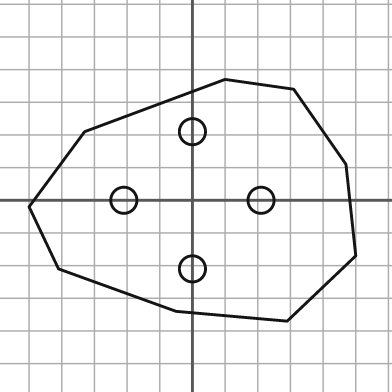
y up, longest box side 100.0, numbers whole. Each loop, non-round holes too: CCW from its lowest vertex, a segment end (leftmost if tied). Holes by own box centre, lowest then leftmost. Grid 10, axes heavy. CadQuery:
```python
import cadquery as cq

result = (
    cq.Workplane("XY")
    .moveTo(29.0, -37.0)
    .lineTo(50.0, -17.0)
    .lineTo(47.0, 11.0)
    .lineTo(31.0, 34.0)
    .lineTo(10.0, 37.0)
    .lineTo(-33.0, 21.0)
    .lineTo(-50.0, -2.0)
    .lineTo(-41.0, -21.0)
    .lineTo(-5.0, -34.0)
    .close()
    .moveTo(0.0, -21.0)
    .circle(4.0)
    .moveTo(-21.0, 0.0)
    .circle(4.0)
    .moveTo(21.0, 0.0)
    .circle(4.0)
    .moveTo(0.0, 21.0)
    .circle(4.0)
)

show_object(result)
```